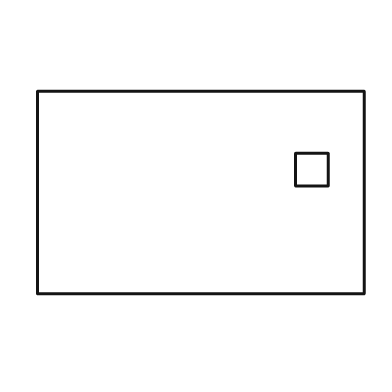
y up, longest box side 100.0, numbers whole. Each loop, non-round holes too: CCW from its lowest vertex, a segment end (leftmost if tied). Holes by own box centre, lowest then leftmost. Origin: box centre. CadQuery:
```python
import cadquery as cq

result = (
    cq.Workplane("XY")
    .moveTo(-50.0, -31.0)
    .lineTo(50.0, -31.0)
    .lineTo(50.0, 31.0)
    .lineTo(-50.0, 31.0)
    .close()
    .moveTo(29.0, 2.0)
    .lineTo(39.0, 2.0)
    .lineTo(39.0, 12.0)
    .lineTo(29.0, 12.0)
    .close()
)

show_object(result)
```